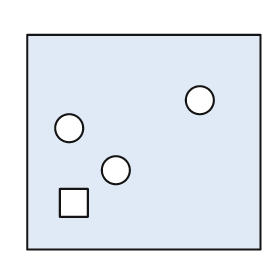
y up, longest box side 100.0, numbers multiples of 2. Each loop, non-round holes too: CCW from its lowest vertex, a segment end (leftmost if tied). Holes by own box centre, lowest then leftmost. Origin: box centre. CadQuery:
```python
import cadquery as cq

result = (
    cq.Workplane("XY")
    .moveTo(-50.0, -46.0)
    .lineTo(50.0, -46.0)
    .lineTo(50.0, 46.0)
    .lineTo(-50.0, 46.0)
    .close()
    .moveTo(-36.0, -32.0)
    .lineTo(-24.0, -32.0)
    .lineTo(-24.0, -20.0)
    .lineTo(-36.0, -20.0)
    .close()
    .moveTo(-12.0, -12.0)
    .circle(6.0)
    .moveTo(-32.0, 6.0)
    .circle(6.0)
    .moveTo(24.0, 18.0)
    .circle(6.0)
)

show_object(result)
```